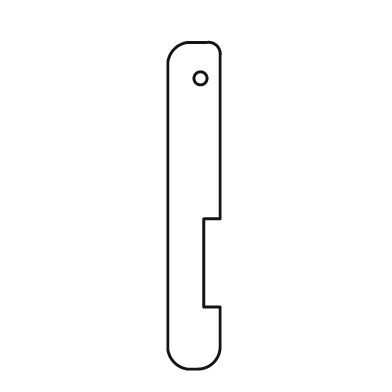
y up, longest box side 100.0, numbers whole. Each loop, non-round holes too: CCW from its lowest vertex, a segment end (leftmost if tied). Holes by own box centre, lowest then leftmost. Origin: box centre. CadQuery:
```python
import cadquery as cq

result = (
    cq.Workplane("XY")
    .moveTo(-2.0, -50.0)
    .lineTo(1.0, -50.0)
    .threePointArc((6.0, -48.0), (8.0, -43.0))
    .lineTo(8.0, -31.0)
    .lineTo(3.0, -31.0)
    .lineTo(3.0, -4.0)
    .lineTo(8.0, -4.0)
    .lineTo(8.0, 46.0)
    .threePointArc((7.0, 49.0), (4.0, 50.0))
    .lineTo(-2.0, 50.0)
    .threePointArc((-6.0, 48.0), (-8.0, 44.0))
    .lineTo(-8.0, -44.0)
    .threePointArc((-6.0, -48.0), (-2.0, -50.0))
    .close()
    .moveTo(2.0, 39.0)
    .circle(2.0)
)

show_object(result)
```